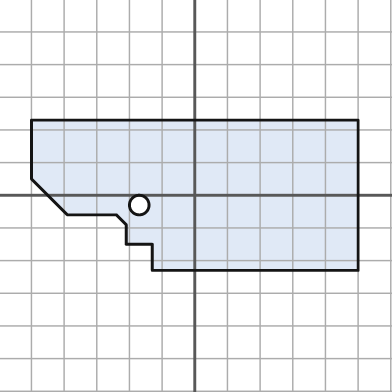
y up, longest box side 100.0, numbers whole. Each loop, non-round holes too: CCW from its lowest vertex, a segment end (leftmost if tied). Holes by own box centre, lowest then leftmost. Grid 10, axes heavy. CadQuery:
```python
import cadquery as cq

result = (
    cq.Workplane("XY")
    .moveTo(-13.0, -23.0)
    .lineTo(50.0, -23.0)
    .lineTo(50.0, 23.0)
    .lineTo(-50.0, 23.0)
    .lineTo(-50.0, 5.0)
    .lineTo(-39.0, -6.0)
    .lineTo(-24.0, -6.0)
    .lineTo(-21.0, -9.0)
    .lineTo(-21.0, -15.0)
    .lineTo(-13.0, -15.0)
    .close()
    .moveTo(-17.0, -3.0)
    .circle(3.0)
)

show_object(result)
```